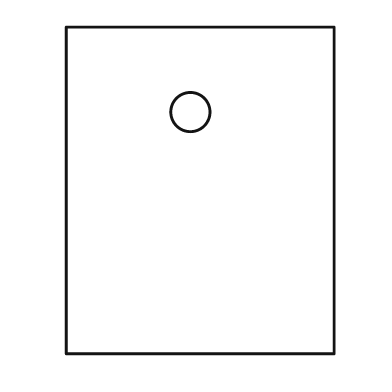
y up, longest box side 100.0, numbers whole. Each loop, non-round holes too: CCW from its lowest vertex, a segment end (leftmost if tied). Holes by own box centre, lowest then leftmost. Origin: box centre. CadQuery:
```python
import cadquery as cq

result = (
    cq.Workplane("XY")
    .moveTo(-41.0, -50.0)
    .lineTo(41.0, -50.0)
    .lineTo(41.0, 50.0)
    .lineTo(-41.0, 50.0)
    .close()
    .moveTo(-3.0, 24.0)
    .circle(6.0)
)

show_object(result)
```